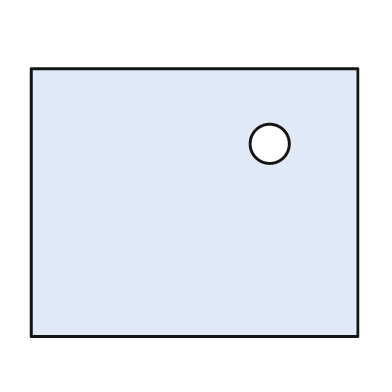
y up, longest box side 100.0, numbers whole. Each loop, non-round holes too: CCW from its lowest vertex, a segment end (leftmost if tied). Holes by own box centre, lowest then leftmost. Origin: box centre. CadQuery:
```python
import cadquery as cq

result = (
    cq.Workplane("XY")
    .moveTo(-50.0, -41.0)
    .lineTo(50.0, -41.0)
    .lineTo(50.0, 41.0)
    .lineTo(-50.0, 41.0)
    .close()
    .moveTo(23.0, 18.0)
    .circle(6.0)
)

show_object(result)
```